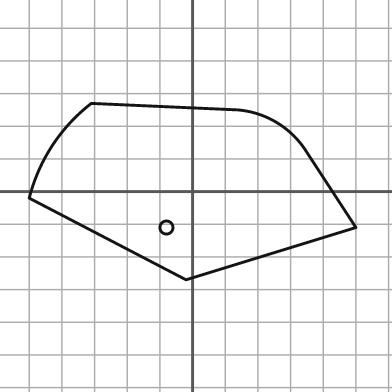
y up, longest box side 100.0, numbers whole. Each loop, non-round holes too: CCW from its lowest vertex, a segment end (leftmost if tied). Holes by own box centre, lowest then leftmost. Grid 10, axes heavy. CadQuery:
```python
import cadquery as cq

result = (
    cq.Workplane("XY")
    .moveTo(-2.0, -27.0)
    .lineTo(50.0, -11.0)
    .lineTo(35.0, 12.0)
    .threePointArc((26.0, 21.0), (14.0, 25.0))
    .lineTo(-31.0, 27.0)
    .threePointArc((-43.0, 14.0), (-50.0, -2.0))
    .close()
    .moveTo(-8.0, -11.0)
    .circle(2.0)
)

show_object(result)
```